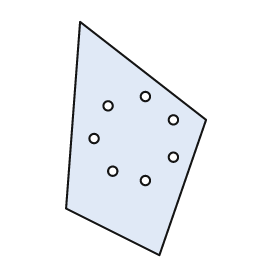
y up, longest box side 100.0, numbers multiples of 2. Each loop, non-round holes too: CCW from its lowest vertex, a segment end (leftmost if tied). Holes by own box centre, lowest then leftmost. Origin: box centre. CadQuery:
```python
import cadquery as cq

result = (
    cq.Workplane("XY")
    .moveTo(10.0, -50.0)
    .lineTo(30.0, 8.0)
    .lineTo(-24.0, 50.0)
    .lineTo(-30.0, -30.0)
    .close()
    .moveTo(4.0, -18.0)
    .circle(2.0)
    .moveTo(-10.0, -14.0)
    .circle(2.0)
    .moveTo(16.0, -8.0)
    .circle(2.0)
    .moveTo(-18.0, 0.0)
    .circle(2.0)
    .moveTo(16.0, 8.0)
    .circle(2.0)
    .moveTo(-12.0, 14.0)
    .circle(2.0)
    .moveTo(4.0, 18.0)
    .circle(2.0)
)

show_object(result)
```